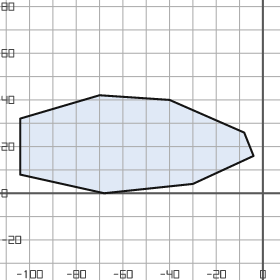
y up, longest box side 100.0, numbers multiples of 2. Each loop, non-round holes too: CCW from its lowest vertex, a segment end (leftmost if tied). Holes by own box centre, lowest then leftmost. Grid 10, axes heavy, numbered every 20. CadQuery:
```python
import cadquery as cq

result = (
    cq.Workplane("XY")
    .moveTo(-68.0, 0.0)
    .lineTo(-30.0, 4.0)
    .lineTo(-4.0, 16.0)
    .lineTo(-8.0, 26.0)
    .lineTo(-40.0, 40.0)
    .lineTo(-70.0, 42.0)
    .lineTo(-104.0, 32.0)
    .lineTo(-104.0, 8.0)
    .close()
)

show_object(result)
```